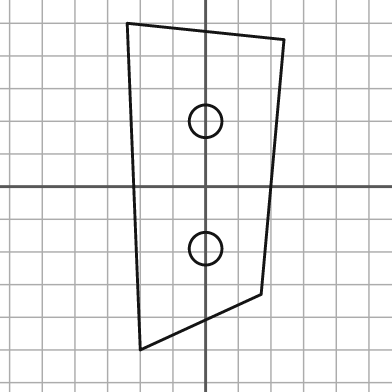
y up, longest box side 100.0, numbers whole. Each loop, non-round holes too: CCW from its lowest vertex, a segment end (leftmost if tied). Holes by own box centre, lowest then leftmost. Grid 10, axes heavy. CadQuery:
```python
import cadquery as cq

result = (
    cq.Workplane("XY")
    .moveTo(-20.0, -50.0)
    .lineTo(17.0, -33.0)
    .lineTo(24.0, 45.0)
    .lineTo(-24.0, 50.0)
    .close()
    .moveTo(0.0, -19.0)
    .circle(5.0)
    .moveTo(0.0, 20.0)
    .circle(5.0)
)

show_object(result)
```